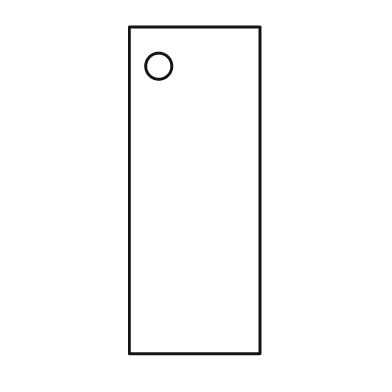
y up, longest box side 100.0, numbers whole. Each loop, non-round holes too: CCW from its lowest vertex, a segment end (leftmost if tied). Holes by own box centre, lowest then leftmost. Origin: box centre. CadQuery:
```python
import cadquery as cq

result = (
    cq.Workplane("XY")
    .moveTo(-20.0, -50.0)
    .lineTo(20.0, -50.0)
    .lineTo(20.0, 50.0)
    .lineTo(-20.0, 50.0)
    .close()
    .moveTo(-11.0, 38.0)
    .circle(4.0)
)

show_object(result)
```